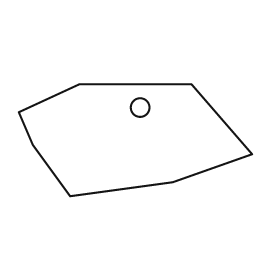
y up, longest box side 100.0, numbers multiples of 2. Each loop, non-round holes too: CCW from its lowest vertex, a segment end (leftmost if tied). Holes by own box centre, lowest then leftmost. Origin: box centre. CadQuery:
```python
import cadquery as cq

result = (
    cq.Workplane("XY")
    .moveTo(-28.0, -24.0)
    .lineTo(16.0, -18.0)
    .lineTo(50.0, -6.0)
    .lineTo(24.0, 24.0)
    .lineTo(-24.0, 24.0)
    .lineTo(-50.0, 12.0)
    .lineTo(-44.0, -2.0)
    .close()
    .moveTo(2.0, 14.0)
    .circle(4.0)
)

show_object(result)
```